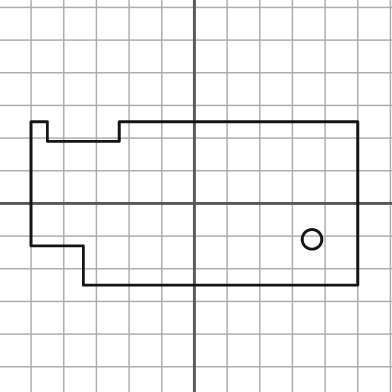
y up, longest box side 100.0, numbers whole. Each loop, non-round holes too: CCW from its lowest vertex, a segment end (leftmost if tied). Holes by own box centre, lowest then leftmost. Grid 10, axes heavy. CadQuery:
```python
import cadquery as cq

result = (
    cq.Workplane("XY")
    .moveTo(-34.0, -25.0)
    .lineTo(50.0, -25.0)
    .lineTo(50.0, 25.0)
    .lineTo(-23.0, 25.0)
    .lineTo(-23.0, 19.0)
    .lineTo(-45.0, 19.0)
    .lineTo(-45.0, 25.0)
    .lineTo(-50.0, 25.0)
    .lineTo(-50.0, -13.0)
    .lineTo(-34.0, -13.0)
    .close()
    .moveTo(36.0, -11.0)
    .circle(3.0)
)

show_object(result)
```